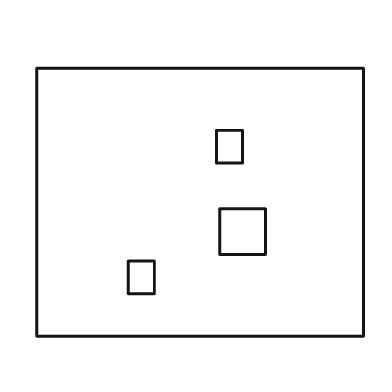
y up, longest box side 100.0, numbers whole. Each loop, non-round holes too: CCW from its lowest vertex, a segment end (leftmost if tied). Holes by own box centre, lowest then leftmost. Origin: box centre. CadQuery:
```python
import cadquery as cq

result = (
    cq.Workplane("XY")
    .moveTo(-50.0, -41.0)
    .lineTo(50.0, -41.0)
    .lineTo(50.0, 41.0)
    .lineTo(-50.0, 41.0)
    .close()
    .moveTo(-22.0, -28.0)
    .lineTo(-14.0, -28.0)
    .lineTo(-14.0, -18.0)
    .lineTo(-22.0, -18.0)
    .close()
    .moveTo(6.0, -16.0)
    .lineTo(20.0, -16.0)
    .lineTo(20.0, -2.0)
    .lineTo(6.0, -2.0)
    .close()
    .moveTo(5.0, 12.0)
    .lineTo(13.0, 12.0)
    .lineTo(13.0, 22.0)
    .lineTo(5.0, 22.0)
    .close()
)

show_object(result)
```